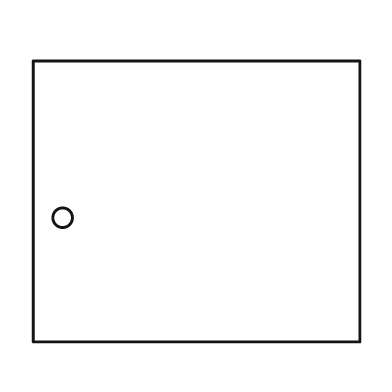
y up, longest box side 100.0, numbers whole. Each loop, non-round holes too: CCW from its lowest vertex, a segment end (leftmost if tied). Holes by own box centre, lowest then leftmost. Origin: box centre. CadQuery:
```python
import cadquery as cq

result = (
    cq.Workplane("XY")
    .moveTo(-50.0, -43.0)
    .lineTo(50.0, -43.0)
    .lineTo(50.0, 43.0)
    .lineTo(-50.0, 43.0)
    .close()
    .moveTo(-41.0, -5.0)
    .circle(3.0)
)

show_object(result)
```